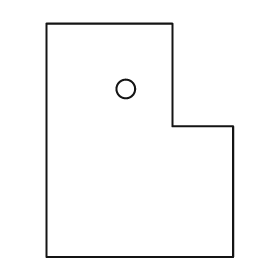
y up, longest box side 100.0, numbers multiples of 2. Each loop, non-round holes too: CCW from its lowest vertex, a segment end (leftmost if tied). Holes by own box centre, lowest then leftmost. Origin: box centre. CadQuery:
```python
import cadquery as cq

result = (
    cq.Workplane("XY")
    .moveTo(-40.0, -50.0)
    .lineTo(40.0, -50.0)
    .lineTo(40.0, 6.0)
    .lineTo(14.0, 6.0)
    .lineTo(14.0, 50.0)
    .lineTo(-40.0, 50.0)
    .close()
    .moveTo(-6.0, 22.0)
    .circle(4.0)
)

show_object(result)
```